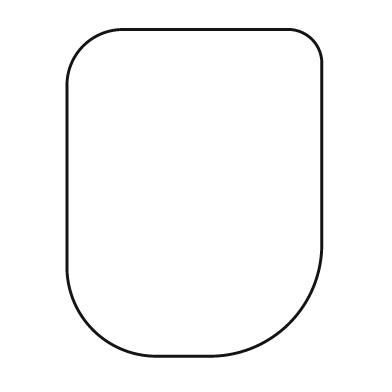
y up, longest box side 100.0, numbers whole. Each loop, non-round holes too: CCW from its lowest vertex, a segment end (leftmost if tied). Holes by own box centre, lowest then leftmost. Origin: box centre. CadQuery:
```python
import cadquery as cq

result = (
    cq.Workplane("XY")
    .moveTo(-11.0, -50.0)
    .lineTo(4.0, -50.0)
    .threePointArc((29.0, -40.0), (39.0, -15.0))
    .lineTo(39.0, 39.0)
    .threePointArc((36.0, 47.0), (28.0, 50.0))
    .lineTo(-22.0, 50.0)
    .threePointArc((-34.0, 45.0), (-39.0, 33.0))
    .lineTo(-39.0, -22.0)
    .threePointArc((-31.0, -42.0), (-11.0, -50.0))
    .close()
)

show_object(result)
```